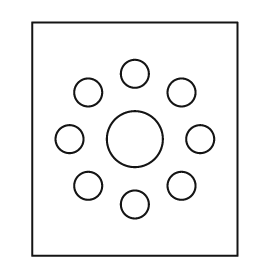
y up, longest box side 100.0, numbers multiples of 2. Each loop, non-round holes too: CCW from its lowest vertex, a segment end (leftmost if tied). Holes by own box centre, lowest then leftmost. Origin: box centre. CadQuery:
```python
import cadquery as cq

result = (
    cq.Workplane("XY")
    .moveTo(-44.0, -50.0)
    .lineTo(44.0, -50.0)
    .lineTo(44.0, 50.0)
    .lineTo(-44.0, 50.0)
    .close()
    .moveTo(0.0, -28.0)
    .circle(6.0)
    .moveTo(-20.0, -20.0)
    .circle(6.0)
    .moveTo(20.0, -20.0)
    .circle(6.0)
    .moveTo(-28.0, 0.0)
    .circle(6.0)
    .moveTo(0.0, 0.0)
    .circle(12.0)
    .moveTo(28.0, 0.0)
    .circle(6.0)
    .moveTo(-20.0, 20.0)
    .circle(6.0)
    .moveTo(20.0, 20.0)
    .circle(6.0)
    .moveTo(0.0, 28.0)
    .circle(6.0)
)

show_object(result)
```